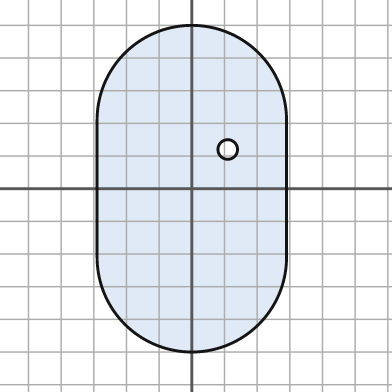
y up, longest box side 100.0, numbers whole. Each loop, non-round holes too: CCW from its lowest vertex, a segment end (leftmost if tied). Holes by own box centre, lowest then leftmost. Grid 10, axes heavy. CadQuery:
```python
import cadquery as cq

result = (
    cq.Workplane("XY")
    .moveTo(-29.0, -21.0)
    .threePointArc((0.0, -50.0), (29.0, -21.0))
    .lineTo(29.0, 21.0)
    .threePointArc((0.0, 50.0), (-29.0, 21.0))
    .close()
    .moveTo(11.0, 12.0)
    .circle(3.0)
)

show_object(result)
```